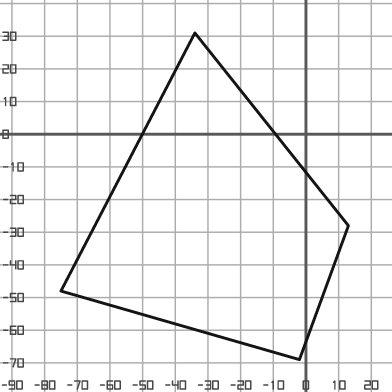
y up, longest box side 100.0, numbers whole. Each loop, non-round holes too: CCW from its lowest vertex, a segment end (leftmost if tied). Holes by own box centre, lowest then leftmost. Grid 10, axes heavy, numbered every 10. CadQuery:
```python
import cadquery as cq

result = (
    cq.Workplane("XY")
    .moveTo(-2.0, -69.0)
    .lineTo(13.0, -28.0)
    .lineTo(-34.0, 31.0)
    .lineTo(-75.0, -48.0)
    .close()
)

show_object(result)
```